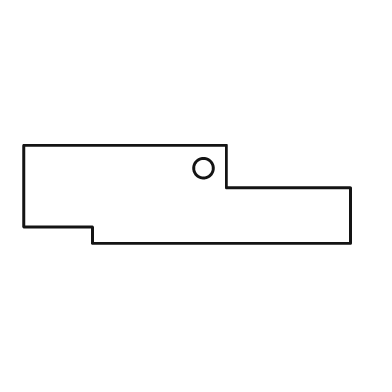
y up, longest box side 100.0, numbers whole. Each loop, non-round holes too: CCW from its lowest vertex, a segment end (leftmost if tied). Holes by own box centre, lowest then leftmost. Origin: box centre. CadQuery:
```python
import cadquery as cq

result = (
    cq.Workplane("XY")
    .moveTo(-29.0, -15.0)
    .lineTo(50.0, -15.0)
    .lineTo(50.0, 2.0)
    .lineTo(12.0, 2.0)
    .lineTo(12.0, 15.0)
    .lineTo(-50.0, 15.0)
    .lineTo(-50.0, -10.0)
    .lineTo(-29.0, -10.0)
    .close()
    .moveTo(5.0, 8.0)
    .circle(3.0)
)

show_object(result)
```